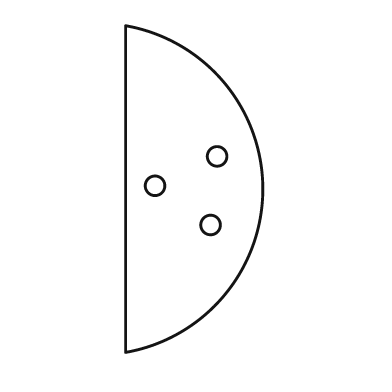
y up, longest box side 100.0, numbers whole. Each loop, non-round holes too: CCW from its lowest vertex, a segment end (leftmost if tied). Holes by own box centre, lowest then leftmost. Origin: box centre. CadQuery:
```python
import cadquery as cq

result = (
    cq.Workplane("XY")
    .moveTo(-21.0, -50.0)
    .threePointArc((21.0, 0.0), (-21.0, 50.0))
    .close()
    .moveTo(5.0, -11.0)
    .circle(3.0)
    .moveTo(-12.0, 1.0)
    .circle(3.0)
    .moveTo(7.0, 10.0)
    .circle(3.0)
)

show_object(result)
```